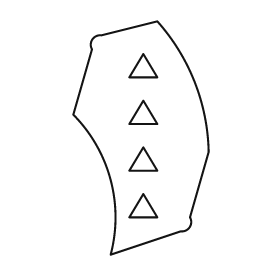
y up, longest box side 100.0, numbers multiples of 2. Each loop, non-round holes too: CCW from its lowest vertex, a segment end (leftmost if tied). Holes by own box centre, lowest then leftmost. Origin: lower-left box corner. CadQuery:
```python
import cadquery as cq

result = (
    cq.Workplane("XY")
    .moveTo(16.0, 0.0)
    .lineTo(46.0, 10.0)
    .threePointArc((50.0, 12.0), (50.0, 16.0))
    .lineTo(58.0, 44.0)
    .threePointArc((52.0, 74.0), (36.0, 100.0))
    .lineTo(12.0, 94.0)
    .threePointArc((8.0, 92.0), (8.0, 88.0))
    .lineTo(0.0, 60.0)
    .threePointArc((16.0, 32.0), (16.0, 0.0))
    .close()
    .moveTo(24.0, 16.0)
    .lineTo(36.0, 16.0)
    .lineTo(30.0, 26.0)
    .close()
    .moveTo(24.0, 36.0)
    .lineTo(36.0, 36.0)
    .lineTo(30.0, 46.0)
    .close()
    .moveTo(24.0, 56.0)
    .lineTo(36.0, 56.0)
    .lineTo(30.0, 66.0)
    .close()
    .moveTo(24.0, 76.0)
    .lineTo(36.0, 76.0)
    .lineTo(30.0, 86.0)
    .close()
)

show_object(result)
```